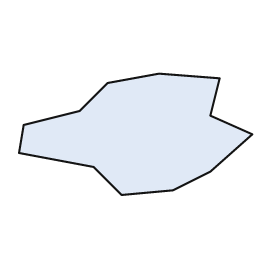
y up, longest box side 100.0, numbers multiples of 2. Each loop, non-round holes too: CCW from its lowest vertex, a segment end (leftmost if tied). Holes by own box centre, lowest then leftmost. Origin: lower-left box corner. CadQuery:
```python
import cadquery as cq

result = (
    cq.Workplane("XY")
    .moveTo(44.0, 0.0)
    .lineTo(66.0, 2.0)
    .lineTo(82.0, 10.0)
    .lineTo(100.0, 26.0)
    .lineTo(82.0, 34.0)
    .lineTo(86.0, 50.0)
    .lineTo(60.0, 52.0)
    .lineTo(38.0, 48.0)
    .lineTo(26.0, 36.0)
    .lineTo(2.0, 30.0)
    .lineTo(0.0, 18.0)
    .lineTo(32.0, 12.0)
    .close()
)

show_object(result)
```